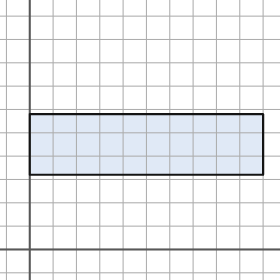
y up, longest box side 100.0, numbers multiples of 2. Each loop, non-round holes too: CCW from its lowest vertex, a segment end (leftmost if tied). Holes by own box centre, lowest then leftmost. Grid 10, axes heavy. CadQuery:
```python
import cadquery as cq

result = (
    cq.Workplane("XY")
    .moveTo(0.0, 32.0)
    .lineTo(100.0, 32.0)
    .lineTo(100.0, 58.0)
    .lineTo(0.0, 58.0)
    .close()
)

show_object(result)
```